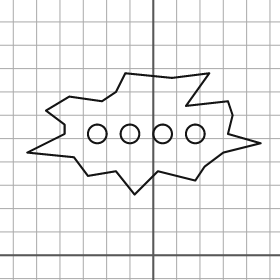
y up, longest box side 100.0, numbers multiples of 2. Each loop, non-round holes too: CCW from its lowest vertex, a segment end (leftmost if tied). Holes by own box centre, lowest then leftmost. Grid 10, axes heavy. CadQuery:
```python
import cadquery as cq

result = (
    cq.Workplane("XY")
    .moveTo(-8.0, 26.0)
    .lineTo(2.0, 36.0)
    .lineTo(18.0, 32.0)
    .lineTo(22.0, 38.0)
    .lineTo(30.0, 44.0)
    .lineTo(46.0, 48.0)
    .lineTo(32.0, 52.0)
    .lineTo(34.0, 60.0)
    .lineTo(32.0, 66.0)
    .lineTo(14.0, 64.0)
    .lineTo(24.0, 78.0)
    .lineTo(8.0, 76.0)
    .lineTo(-12.0, 78.0)
    .lineTo(-16.0, 70.0)
    .lineTo(-22.0, 66.0)
    .lineTo(-36.0, 68.0)
    .lineTo(-46.0, 62.0)
    .lineTo(-38.0, 56.0)
    .lineTo(-38.0, 52.0)
    .lineTo(-54.0, 44.0)
    .lineTo(-34.0, 42.0)
    .lineTo(-28.0, 34.0)
    .lineTo(-16.0, 36.0)
    .close()
    .moveTo(-24.0, 52.0)
    .circle(4.0)
    .moveTo(-10.0, 52.0)
    .circle(4.0)
    .moveTo(4.0, 52.0)
    .circle(4.0)
    .moveTo(18.0, 52.0)
    .circle(4.0)
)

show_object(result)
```